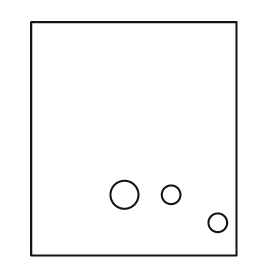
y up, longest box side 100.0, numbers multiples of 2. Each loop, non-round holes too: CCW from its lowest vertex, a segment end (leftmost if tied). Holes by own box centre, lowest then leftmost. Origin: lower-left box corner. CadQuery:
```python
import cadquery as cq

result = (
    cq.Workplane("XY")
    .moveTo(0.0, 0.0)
    .lineTo(88.0, 0.0)
    .lineTo(88.0, 100.0)
    .lineTo(0.0, 100.0)
    .close()
    .moveTo(80.0, 14.0)
    .circle(4.0)
    .moveTo(40.0, 26.0)
    .circle(6.0)
    .moveTo(60.0, 26.0)
    .circle(4.0)
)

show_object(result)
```